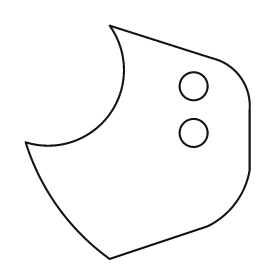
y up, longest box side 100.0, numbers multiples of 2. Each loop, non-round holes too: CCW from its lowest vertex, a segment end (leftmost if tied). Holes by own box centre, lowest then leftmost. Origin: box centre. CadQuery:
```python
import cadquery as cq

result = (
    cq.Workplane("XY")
    .moveTo(-12.0, -50.0)
    .lineTo(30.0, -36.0)
    .threePointArc((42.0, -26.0), (48.0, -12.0))
    .lineTo(48.0, 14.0)
    .threePointArc((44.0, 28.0), (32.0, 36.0))
    .lineTo(-12.0, 50.0)
    .threePointArc((-12.0, 12.0), (-48.0, 0.0))
    .threePointArc((-34.0, -28.0), (-12.0, -50.0))
    .close()
    .moveTo(24.0, 4.0)
    .circle(6.0)
    .moveTo(24.0, 24.0)
    .circle(6.0)
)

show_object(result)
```